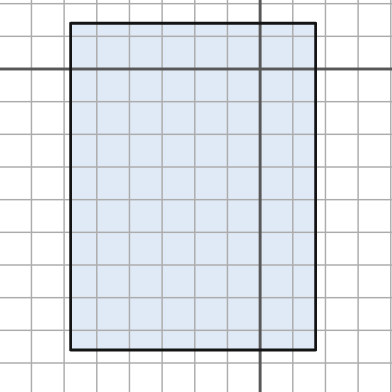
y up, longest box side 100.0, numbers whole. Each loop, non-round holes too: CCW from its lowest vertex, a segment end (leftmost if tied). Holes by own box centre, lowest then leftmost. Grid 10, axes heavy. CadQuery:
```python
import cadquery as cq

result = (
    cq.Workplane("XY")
    .moveTo(-58.0, -86.0)
    .lineTo(17.0, -86.0)
    .lineTo(17.0, 14.0)
    .lineTo(-58.0, 14.0)
    .close()
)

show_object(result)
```